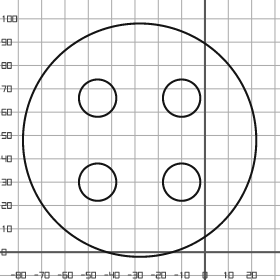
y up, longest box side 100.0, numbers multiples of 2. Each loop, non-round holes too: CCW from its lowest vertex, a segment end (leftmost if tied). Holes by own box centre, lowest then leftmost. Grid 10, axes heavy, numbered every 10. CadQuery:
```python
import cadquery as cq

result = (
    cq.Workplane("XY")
    .moveTo(-28.0, 48.0)
    .circle(50.0)
    .moveTo(-46.0, 30.0)
    .circle(8.0)
    .moveTo(-10.0, 30.0)
    .circle(8.0)
    .moveTo(-46.0, 66.0)
    .circle(8.0)
    .moveTo(-10.0, 66.0)
    .circle(8.0)
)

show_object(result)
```